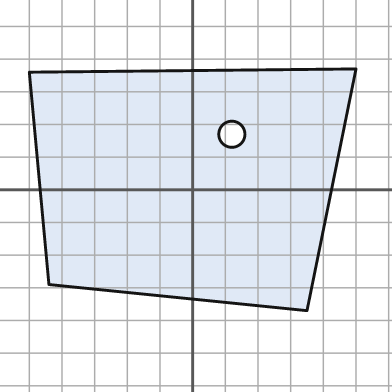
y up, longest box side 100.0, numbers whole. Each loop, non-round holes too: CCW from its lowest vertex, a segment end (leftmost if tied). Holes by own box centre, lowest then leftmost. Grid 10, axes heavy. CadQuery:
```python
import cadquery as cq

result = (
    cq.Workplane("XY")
    .moveTo(35.0, -37.0)
    .lineTo(50.0, 37.0)
    .lineTo(-50.0, 36.0)
    .lineTo(-44.0, -29.0)
    .close()
    .moveTo(12.0, 17.0)
    .circle(4.0)
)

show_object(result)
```